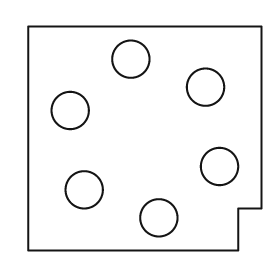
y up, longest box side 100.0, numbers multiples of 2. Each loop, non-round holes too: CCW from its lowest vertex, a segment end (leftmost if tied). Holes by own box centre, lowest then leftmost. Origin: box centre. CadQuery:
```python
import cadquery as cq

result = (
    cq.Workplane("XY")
    .moveTo(-50.0, -48.0)
    .lineTo(40.0, -48.0)
    .lineTo(40.0, -30.0)
    .lineTo(50.0, -30.0)
    .lineTo(50.0, 48.0)
    .lineTo(-50.0, 48.0)
    .close()
    .moveTo(6.0, -34.0)
    .circle(8.0)
    .moveTo(-26.0, -22.0)
    .circle(8.0)
    .moveTo(32.0, -12.0)
    .circle(8.0)
    .moveTo(-32.0, 12.0)
    .circle(8.0)
    .moveTo(26.0, 22.0)
    .circle(8.0)
    .moveTo(-6.0, 34.0)
    .circle(8.0)
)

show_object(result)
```